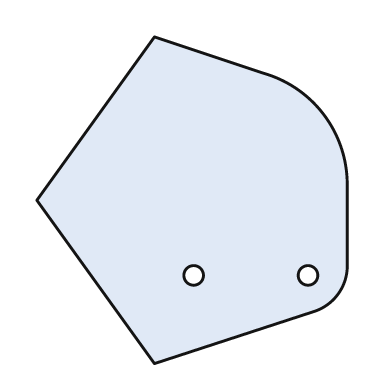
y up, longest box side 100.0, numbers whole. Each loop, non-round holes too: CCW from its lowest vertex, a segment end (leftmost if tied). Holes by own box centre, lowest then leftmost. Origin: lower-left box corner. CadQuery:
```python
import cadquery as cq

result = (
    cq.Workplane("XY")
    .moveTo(36.0, 0.0)
    .lineTo(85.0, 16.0)
    .threePointArc((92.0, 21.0), (95.0, 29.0))
    .lineTo(95.0, 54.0)
    .threePointArc((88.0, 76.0), (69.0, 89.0))
    .lineTo(36.0, 100.0)
    .lineTo(0.0, 50.0)
    .close()
    .moveTo(48.0, 27.0)
    .circle(3.0)
    .moveTo(83.0, 27.0)
    .circle(3.0)
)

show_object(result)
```